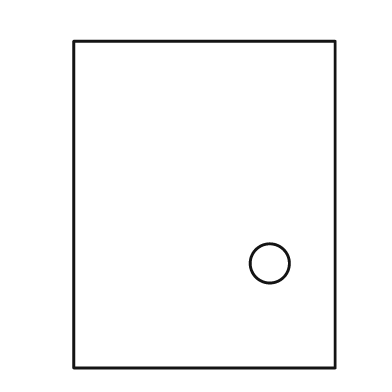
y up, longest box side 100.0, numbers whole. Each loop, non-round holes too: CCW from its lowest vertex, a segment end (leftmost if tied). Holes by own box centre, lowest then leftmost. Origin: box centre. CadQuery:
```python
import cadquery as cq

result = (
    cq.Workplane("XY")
    .moveTo(-40.0, -50.0)
    .lineTo(40.0, -50.0)
    .lineTo(40.0, 50.0)
    .lineTo(-40.0, 50.0)
    .close()
    .moveTo(20.0, -18.0)
    .circle(6.0)
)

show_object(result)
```